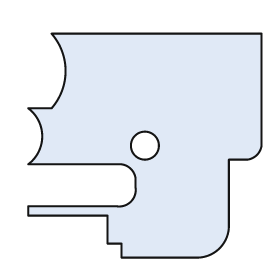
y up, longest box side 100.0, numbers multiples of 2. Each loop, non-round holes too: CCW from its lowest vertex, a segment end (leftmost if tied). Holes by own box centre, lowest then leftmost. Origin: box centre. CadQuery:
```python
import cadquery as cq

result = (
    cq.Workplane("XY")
    .moveTo(-10.0, -48.0)
    .lineTo(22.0, -48.0)
    .threePointArc((32.0, -44.0), (36.0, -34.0))
    .lineTo(36.0, -6.0)
    .lineTo(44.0, -6.0)
    .threePointArc((48.0, -4.0), (50.0, 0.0))
    .lineTo(50.0, 48.0)
    .lineTo(-40.0, 48.0)
    .threePointArc((-34.0, 32.0), (-40.0, 16.0))
    .lineTo(-50.0, 16.0)
    .threePointArc((-44.0, 4.0), (-50.0, -8.0))
    .lineTo(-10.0, -8.0)
    .threePointArc((-6.0, -10.0), (-4.0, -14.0))
    .lineTo(-4.0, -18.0)
    .threePointArc((-6.0, -24.0), (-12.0, -26.0))
    .lineTo(-50.0, -26.0)
    .lineTo(-50.0, -30.0)
    .lineTo(-16.0, -30.0)
    .lineTo(-16.0, -42.0)
    .lineTo(-10.0, -42.0)
    .close()
    .moveTo(0.0, 0.0)
    .circle(6.0)
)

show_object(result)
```